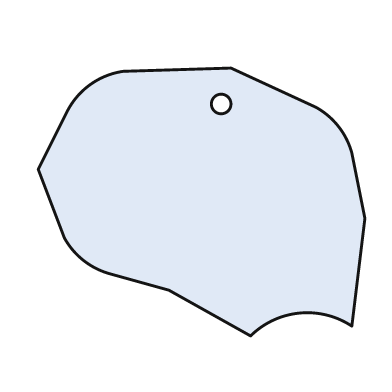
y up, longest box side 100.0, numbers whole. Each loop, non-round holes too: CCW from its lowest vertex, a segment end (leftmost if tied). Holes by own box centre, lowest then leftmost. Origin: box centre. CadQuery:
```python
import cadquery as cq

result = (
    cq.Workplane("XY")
    .moveTo(15.0, -41.0)
    .threePointArc((30.0, -34.0), (46.0, -38.0))
    .lineTo(50.0, -5.0)
    .lineTo(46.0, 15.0)
    .threePointArc((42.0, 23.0), (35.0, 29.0))
    .lineTo(9.0, 41.0)
    .lineTo(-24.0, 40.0)
    .threePointArc((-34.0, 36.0), (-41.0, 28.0))
    .lineTo(-50.0, 10.0)
    .lineTo(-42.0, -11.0)
    .threePointArc((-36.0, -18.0), (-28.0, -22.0))
    .lineTo(-10.0, -27.0)
    .close()
    .moveTo(6.0, 30.0)
    .circle(3.0)
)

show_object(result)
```